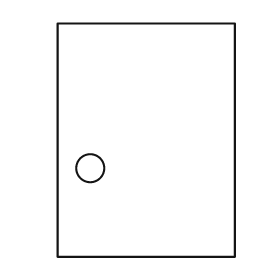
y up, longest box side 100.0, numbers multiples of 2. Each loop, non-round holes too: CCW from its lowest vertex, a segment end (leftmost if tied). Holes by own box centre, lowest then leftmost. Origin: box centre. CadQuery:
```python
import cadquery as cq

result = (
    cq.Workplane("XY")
    .moveTo(-38.0, -50.0)
    .lineTo(38.0, -50.0)
    .lineTo(38.0, 50.0)
    .lineTo(-38.0, 50.0)
    .close()
    .moveTo(-24.0, -12.0)
    .circle(6.0)
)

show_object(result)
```